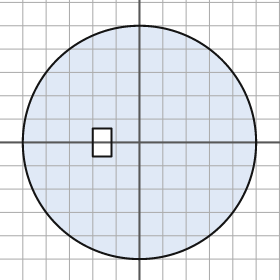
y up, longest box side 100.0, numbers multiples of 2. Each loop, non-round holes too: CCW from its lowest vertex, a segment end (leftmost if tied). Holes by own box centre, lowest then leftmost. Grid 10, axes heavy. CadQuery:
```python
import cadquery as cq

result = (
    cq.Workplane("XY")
    .moveTo(0.0, 0.0)
    .circle(50.0)
    .moveTo(-20.0, -6.0)
    .lineTo(-12.0, -6.0)
    .lineTo(-12.0, 6.0)
    .lineTo(-20.0, 6.0)
    .close()
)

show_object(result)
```